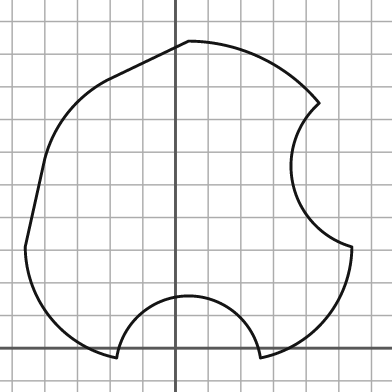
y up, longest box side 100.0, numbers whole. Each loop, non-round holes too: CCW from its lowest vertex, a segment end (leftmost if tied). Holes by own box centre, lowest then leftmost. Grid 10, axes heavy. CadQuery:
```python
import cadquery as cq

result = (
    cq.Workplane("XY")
    .moveTo(-18.0, -3.0)
    .threePointArc((4.0, 16.0), (26.0, -3.0))
    .threePointArc((46.0, 9.0), (54.0, 31.0))
    .threePointArc((36.0, 50.0), (44.0, 75.0))
    .threePointArc((26.0, 89.0), (4.0, 94.0))
    .lineTo(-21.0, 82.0)
    .threePointArc((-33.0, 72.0), (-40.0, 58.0))
    .lineTo(-46.0, 31.0)
    .threePointArc((-38.0, 9.0), (-18.0, -3.0))
    .close()
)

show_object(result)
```